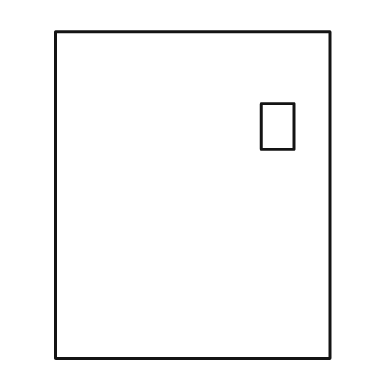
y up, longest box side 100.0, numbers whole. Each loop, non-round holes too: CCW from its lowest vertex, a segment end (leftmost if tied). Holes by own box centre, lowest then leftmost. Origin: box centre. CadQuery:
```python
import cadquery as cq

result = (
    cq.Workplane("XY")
    .moveTo(-42.0, -50.0)
    .lineTo(42.0, -50.0)
    .lineTo(42.0, 50.0)
    .lineTo(-42.0, 50.0)
    .close()
    .moveTo(21.0, 14.0)
    .lineTo(31.0, 14.0)
    .lineTo(31.0, 28.0)
    .lineTo(21.0, 28.0)
    .close()
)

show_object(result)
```